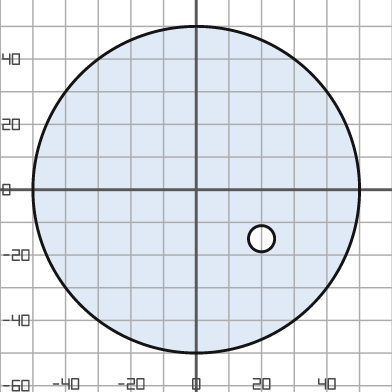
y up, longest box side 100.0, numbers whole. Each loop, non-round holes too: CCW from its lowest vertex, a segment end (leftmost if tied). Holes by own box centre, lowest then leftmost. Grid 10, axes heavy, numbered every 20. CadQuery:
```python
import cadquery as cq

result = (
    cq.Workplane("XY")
    .moveTo(0.0, 0.0)
    .circle(50.0)
    .moveTo(20.0, -15.0)
    .circle(4.0)
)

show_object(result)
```